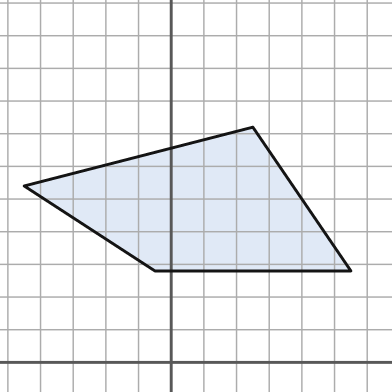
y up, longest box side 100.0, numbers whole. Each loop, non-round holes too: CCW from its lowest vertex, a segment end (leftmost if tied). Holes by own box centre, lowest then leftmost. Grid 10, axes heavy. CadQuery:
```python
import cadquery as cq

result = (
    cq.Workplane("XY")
    .moveTo(-5.0, 28.0)
    .lineTo(55.0, 28.0)
    .lineTo(25.0, 72.0)
    .lineTo(-45.0, 54.0)
    .close()
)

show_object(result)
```